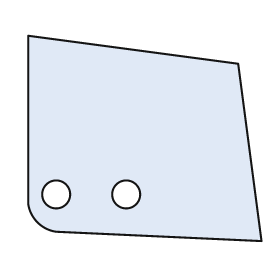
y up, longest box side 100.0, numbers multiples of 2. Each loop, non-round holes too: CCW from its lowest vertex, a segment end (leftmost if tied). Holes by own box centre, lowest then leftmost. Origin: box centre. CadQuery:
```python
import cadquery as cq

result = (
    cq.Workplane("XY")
    .moveTo(50.0, -44.0)
    .lineTo(40.0, 32.0)
    .lineTo(-50.0, 44.0)
    .lineTo(-50.0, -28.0)
    .threePointArc((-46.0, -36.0), (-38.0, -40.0))
    .close()
    .moveTo(-38.0, -24.0)
    .circle(6.0)
    .moveTo(-8.0, -24.0)
    .circle(6.0)
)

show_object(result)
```